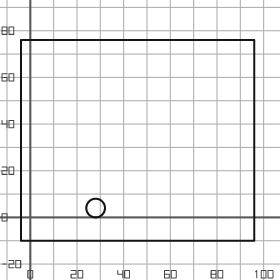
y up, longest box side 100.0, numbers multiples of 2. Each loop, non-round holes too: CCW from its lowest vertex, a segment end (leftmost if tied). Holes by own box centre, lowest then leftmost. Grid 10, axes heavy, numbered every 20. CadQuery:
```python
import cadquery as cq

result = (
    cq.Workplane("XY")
    .moveTo(-4.0, -10.0)
    .lineTo(96.0, -10.0)
    .lineTo(96.0, 76.0)
    .lineTo(-4.0, 76.0)
    .close()
    .moveTo(28.0, 4.0)
    .circle(4.0)
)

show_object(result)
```